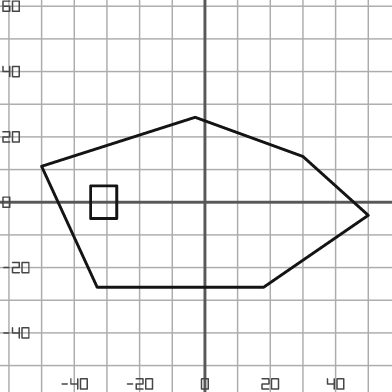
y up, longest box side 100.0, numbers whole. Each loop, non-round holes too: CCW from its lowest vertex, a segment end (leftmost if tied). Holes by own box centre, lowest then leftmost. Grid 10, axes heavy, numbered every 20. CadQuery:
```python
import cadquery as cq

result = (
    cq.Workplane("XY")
    .moveTo(-33.0, -26.0)
    .lineTo(18.0, -26.0)
    .lineTo(50.0, -4.0)
    .lineTo(30.0, 14.0)
    .lineTo(-3.0, 26.0)
    .lineTo(-50.0, 11.0)
    .close()
    .moveTo(-35.0, -5.0)
    .lineTo(-27.0, -5.0)
    .lineTo(-27.0, 5.0)
    .lineTo(-35.0, 5.0)
    .close()
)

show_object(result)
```